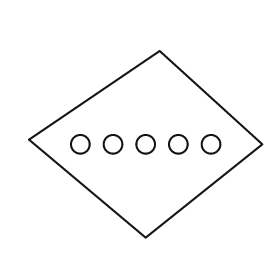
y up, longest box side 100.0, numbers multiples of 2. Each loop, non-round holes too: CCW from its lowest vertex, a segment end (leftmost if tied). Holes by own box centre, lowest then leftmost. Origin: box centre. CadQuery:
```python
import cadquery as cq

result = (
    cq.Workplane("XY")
    .moveTo(0.0, -40.0)
    .lineTo(50.0, 0.0)
    .lineTo(6.0, 40.0)
    .lineTo(-50.0, 2.0)
    .close()
    .moveTo(-28.0, 0.0)
    .circle(4.0)
    .moveTo(-14.0, 0.0)
    .circle(4.0)
    .moveTo(0.0, 0.0)
    .circle(4.0)
    .moveTo(14.0, 0.0)
    .circle(4.0)
    .moveTo(28.0, 0.0)
    .circle(4.0)
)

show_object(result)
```